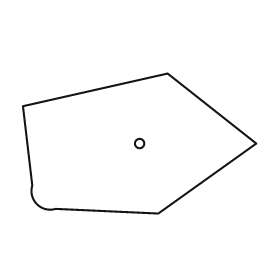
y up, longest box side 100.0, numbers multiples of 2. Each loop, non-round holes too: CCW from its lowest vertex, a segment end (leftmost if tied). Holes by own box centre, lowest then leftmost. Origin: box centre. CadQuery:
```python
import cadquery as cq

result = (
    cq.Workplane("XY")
    .moveTo(8.0, -30.0)
    .lineTo(50.0, 0.0)
    .lineTo(12.0, 30.0)
    .lineTo(-50.0, 16.0)
    .lineTo(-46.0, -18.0)
    .threePointArc((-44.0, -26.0), (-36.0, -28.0))
    .close()
    .moveTo(0.0, 0.0)
    .circle(2.0)
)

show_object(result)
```